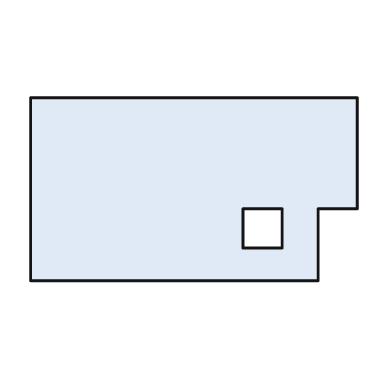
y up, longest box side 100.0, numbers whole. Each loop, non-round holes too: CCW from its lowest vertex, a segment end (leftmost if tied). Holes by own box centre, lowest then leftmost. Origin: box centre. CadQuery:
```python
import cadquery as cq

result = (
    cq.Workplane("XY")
    .moveTo(-50.0, -28.0)
    .lineTo(38.0, -28.0)
    .lineTo(38.0, -6.0)
    .lineTo(50.0, -6.0)
    .lineTo(50.0, 28.0)
    .lineTo(-50.0, 28.0)
    .close()
    .moveTo(15.0, -18.0)
    .lineTo(27.0, -18.0)
    .lineTo(27.0, -6.0)
    .lineTo(15.0, -6.0)
    .close()
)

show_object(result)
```